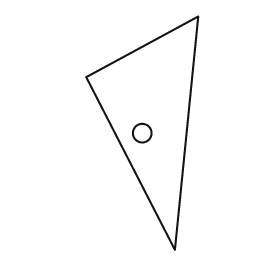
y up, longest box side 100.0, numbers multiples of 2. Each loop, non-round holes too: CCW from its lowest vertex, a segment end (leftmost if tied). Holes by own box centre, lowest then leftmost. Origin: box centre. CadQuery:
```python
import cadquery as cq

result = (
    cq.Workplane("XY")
    .moveTo(14.0, -50.0)
    .lineTo(24.0, 50.0)
    .lineTo(-24.0, 24.0)
    .close()
    .moveTo(0.0, 0.0)
    .circle(4.0)
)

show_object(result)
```